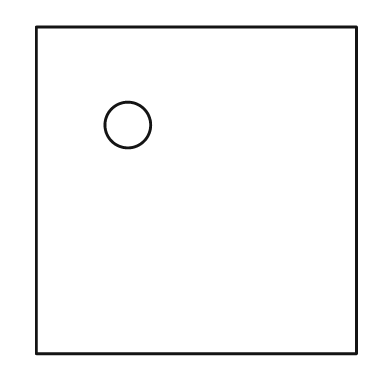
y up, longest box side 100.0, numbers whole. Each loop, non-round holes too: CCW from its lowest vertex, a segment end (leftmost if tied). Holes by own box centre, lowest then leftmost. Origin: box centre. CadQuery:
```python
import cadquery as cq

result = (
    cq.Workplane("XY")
    .moveTo(-49.0, -50.0)
    .lineTo(49.0, -50.0)
    .lineTo(49.0, 50.0)
    .lineTo(-49.0, 50.0)
    .close()
    .moveTo(-21.0, 20.0)
    .circle(7.0)
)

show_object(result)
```